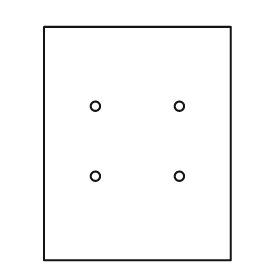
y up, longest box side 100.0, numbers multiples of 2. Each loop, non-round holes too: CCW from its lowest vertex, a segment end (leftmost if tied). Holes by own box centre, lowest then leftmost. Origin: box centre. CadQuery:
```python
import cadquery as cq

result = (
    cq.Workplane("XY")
    .moveTo(-40.0, -50.0)
    .lineTo(40.0, -50.0)
    .lineTo(40.0, 50.0)
    .lineTo(-40.0, 50.0)
    .close()
    .moveTo(-18.0, -14.0)
    .circle(2.0)
    .moveTo(18.0, -14.0)
    .circle(2.0)
    .moveTo(-18.0, 16.0)
    .circle(2.0)
    .moveTo(18.0, 16.0)
    .circle(2.0)
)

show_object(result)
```